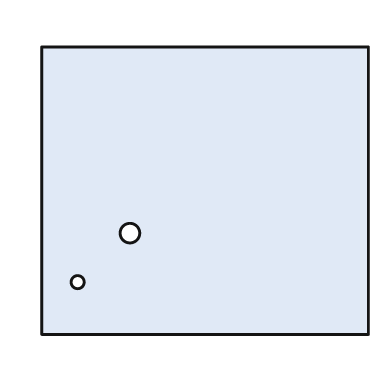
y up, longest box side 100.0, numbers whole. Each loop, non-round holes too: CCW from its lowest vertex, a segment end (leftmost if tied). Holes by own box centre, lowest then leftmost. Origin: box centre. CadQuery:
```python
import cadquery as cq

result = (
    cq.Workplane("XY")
    .moveTo(-50.0, -44.0)
    .lineTo(50.0, -44.0)
    .lineTo(50.0, 44.0)
    .lineTo(-50.0, 44.0)
    .close()
    .moveTo(-39.0, -28.0)
    .circle(2.0)
    .moveTo(-23.0, -13.0)
    .circle(3.0)
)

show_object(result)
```